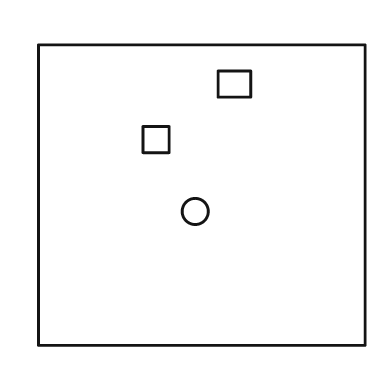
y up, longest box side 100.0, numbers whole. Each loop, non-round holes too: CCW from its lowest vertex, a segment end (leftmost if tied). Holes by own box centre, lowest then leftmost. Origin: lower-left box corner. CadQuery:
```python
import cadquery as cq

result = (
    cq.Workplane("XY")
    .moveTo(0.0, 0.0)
    .lineTo(100.0, 0.0)
    .lineTo(100.0, 92.0)
    .lineTo(0.0, 92.0)
    .close()
    .moveTo(48.0, 41.0)
    .circle(4.0)
    .moveTo(32.0, 59.0)
    .lineTo(40.0, 59.0)
    .lineTo(40.0, 67.0)
    .lineTo(32.0, 67.0)
    .close()
    .moveTo(55.0, 76.0)
    .lineTo(65.0, 76.0)
    .lineTo(65.0, 84.0)
    .lineTo(55.0, 84.0)
    .close()
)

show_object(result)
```